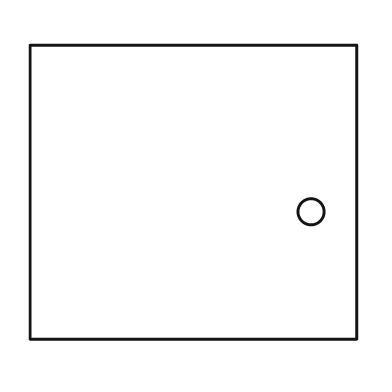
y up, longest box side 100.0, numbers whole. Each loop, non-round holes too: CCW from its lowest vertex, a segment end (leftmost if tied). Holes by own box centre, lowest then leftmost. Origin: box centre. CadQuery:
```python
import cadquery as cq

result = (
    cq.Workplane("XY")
    .moveTo(-50.0, -45.0)
    .lineTo(50.0, -45.0)
    .lineTo(50.0, 45.0)
    .lineTo(-50.0, 45.0)
    .close()
    .moveTo(36.0, -6.0)
    .circle(4.0)
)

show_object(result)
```